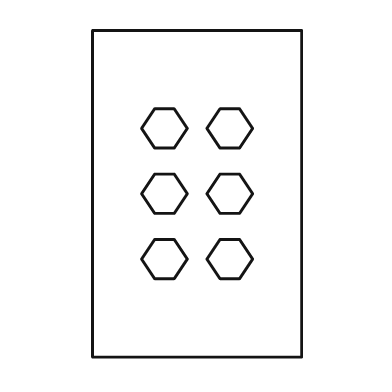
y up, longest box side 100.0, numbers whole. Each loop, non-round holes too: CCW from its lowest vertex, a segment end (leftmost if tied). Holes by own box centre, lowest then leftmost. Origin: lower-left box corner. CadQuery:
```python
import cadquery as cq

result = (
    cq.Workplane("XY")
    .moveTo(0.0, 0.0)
    .lineTo(64.0, 0.0)
    .lineTo(64.0, 100.0)
    .lineTo(0.0, 100.0)
    .close()
    .moveTo(19.0, 24.0)
    .lineTo(25.0, 24.0)
    .lineTo(29.0, 30.0)
    .lineTo(25.0, 36.0)
    .lineTo(19.0, 36.0)
    .lineTo(15.0, 30.0)
    .close()
    .moveTo(39.0, 24.0)
    .lineTo(45.0, 24.0)
    .lineTo(49.0, 30.0)
    .lineTo(45.0, 36.0)
    .lineTo(39.0, 36.0)
    .lineTo(35.0, 30.0)
    .close()
    .moveTo(19.0, 44.0)
    .lineTo(25.0, 44.0)
    .lineTo(29.0, 50.0)
    .lineTo(25.0, 56.0)
    .lineTo(19.0, 56.0)
    .lineTo(15.0, 50.0)
    .close()
    .moveTo(39.0, 44.0)
    .lineTo(45.0, 44.0)
    .lineTo(49.0, 50.0)
    .lineTo(45.0, 56.0)
    .lineTo(39.0, 56.0)
    .lineTo(35.0, 50.0)
    .close()
    .moveTo(19.0, 64.0)
    .lineTo(25.0, 64.0)
    .lineTo(29.0, 70.0)
    .lineTo(25.0, 76.0)
    .lineTo(19.0, 76.0)
    .lineTo(15.0, 70.0)
    .close()
    .moveTo(39.0, 64.0)
    .lineTo(45.0, 64.0)
    .lineTo(49.0, 70.0)
    .lineTo(45.0, 76.0)
    .lineTo(39.0, 76.0)
    .lineTo(35.0, 70.0)
    .close()
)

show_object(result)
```